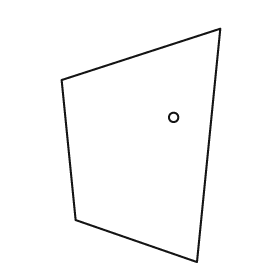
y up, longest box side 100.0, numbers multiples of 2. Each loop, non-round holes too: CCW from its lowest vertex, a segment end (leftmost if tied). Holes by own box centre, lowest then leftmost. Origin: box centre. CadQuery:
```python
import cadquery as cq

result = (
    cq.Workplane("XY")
    .moveTo(24.0, -50.0)
    .lineTo(34.0, 50.0)
    .lineTo(-34.0, 28.0)
    .lineTo(-28.0, -32.0)
    .close()
    .moveTo(14.0, 12.0)
    .circle(2.0)
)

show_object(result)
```